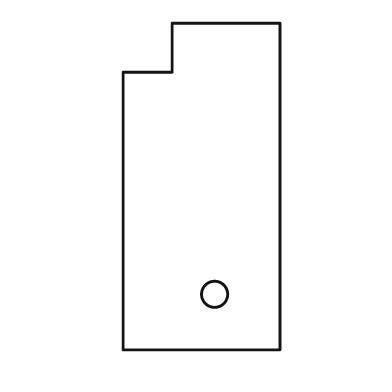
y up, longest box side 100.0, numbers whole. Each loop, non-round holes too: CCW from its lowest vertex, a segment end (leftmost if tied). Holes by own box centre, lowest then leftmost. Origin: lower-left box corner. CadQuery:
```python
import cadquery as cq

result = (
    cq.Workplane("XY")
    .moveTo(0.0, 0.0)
    .lineTo(48.0, 0.0)
    .lineTo(48.0, 100.0)
    .lineTo(15.0, 100.0)
    .lineTo(15.0, 85.0)
    .lineTo(0.0, 85.0)
    .close()
    .moveTo(28.0, 17.0)
    .circle(4.0)
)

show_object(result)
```